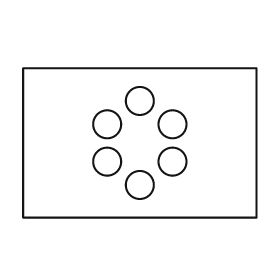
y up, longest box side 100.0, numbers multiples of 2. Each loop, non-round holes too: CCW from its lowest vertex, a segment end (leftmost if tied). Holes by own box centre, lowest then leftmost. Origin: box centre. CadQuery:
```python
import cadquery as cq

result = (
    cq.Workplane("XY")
    .moveTo(-50.0, -32.0)
    .lineTo(50.0, -32.0)
    .lineTo(50.0, 32.0)
    .lineTo(-50.0, 32.0)
    .close()
    .moveTo(0.0, -18.0)
    .circle(6.0)
    .moveTo(-14.0, -8.0)
    .circle(6.0)
    .moveTo(14.0, -8.0)
    .circle(6.0)
    .moveTo(-14.0, 8.0)
    .circle(6.0)
    .moveTo(14.0, 8.0)
    .circle(6.0)
    .moveTo(0.0, 18.0)
    .circle(6.0)
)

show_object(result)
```